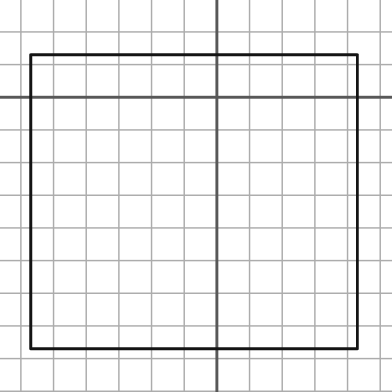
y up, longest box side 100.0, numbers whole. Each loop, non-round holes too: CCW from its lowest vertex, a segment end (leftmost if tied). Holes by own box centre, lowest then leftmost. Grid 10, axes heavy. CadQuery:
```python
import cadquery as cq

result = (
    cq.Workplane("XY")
    .moveTo(-57.0, -77.0)
    .lineTo(43.0, -77.0)
    .lineTo(43.0, 13.0)
    .lineTo(-57.0, 13.0)
    .close()
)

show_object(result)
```